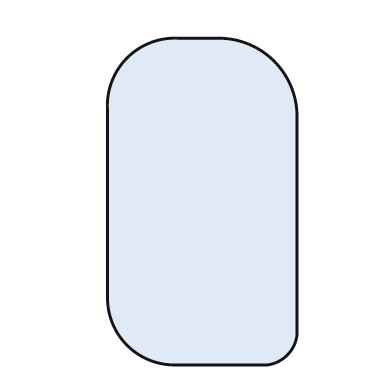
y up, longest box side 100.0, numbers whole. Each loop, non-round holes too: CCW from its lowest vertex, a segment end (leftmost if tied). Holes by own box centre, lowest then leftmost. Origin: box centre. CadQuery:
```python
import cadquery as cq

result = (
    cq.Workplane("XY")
    .moveTo(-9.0, -50.0)
    .lineTo(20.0, -50.0)
    .threePointArc((26.0, -47.0), (29.0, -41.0))
    .lineTo(29.0, 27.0)
    .threePointArc((22.0, 43.0), (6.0, 50.0))
    .lineTo(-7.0, 50.0)
    .threePointArc((-23.0, 44.0), (-29.0, 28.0))
    .lineTo(-29.0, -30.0)
    .threePointArc((-23.0, -44.0), (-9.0, -50.0))
    .close()
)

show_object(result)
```